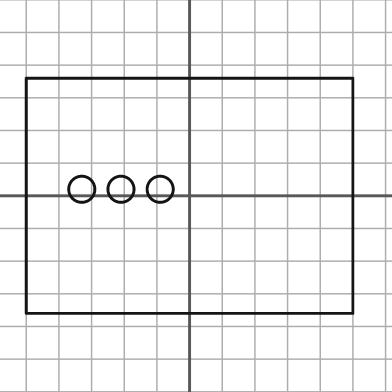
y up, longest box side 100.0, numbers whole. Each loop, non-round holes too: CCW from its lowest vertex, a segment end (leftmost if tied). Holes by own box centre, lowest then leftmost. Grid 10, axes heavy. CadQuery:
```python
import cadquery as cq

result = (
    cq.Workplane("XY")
    .moveTo(-50.0, -36.0)
    .lineTo(50.0, -36.0)
    .lineTo(50.0, 36.0)
    .lineTo(-50.0, 36.0)
    .close()
    .moveTo(-33.0, 2.0)
    .circle(4.0)
    .moveTo(-21.0, 2.0)
    .circle(4.0)
    .moveTo(-9.0, 2.0)
    .circle(4.0)
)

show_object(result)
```